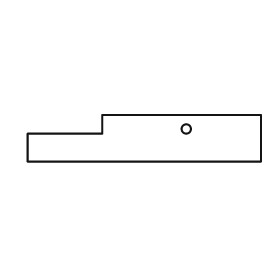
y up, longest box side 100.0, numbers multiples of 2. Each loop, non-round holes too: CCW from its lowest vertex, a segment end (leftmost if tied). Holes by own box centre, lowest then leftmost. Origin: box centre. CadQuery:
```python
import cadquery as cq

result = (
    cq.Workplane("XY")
    .moveTo(-50.0, -10.0)
    .lineTo(50.0, -10.0)
    .lineTo(50.0, 10.0)
    .lineTo(-18.0, 10.0)
    .lineTo(-18.0, 2.0)
    .lineTo(-50.0, 2.0)
    .close()
    .moveTo(18.0, 4.0)
    .circle(2.0)
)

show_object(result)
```